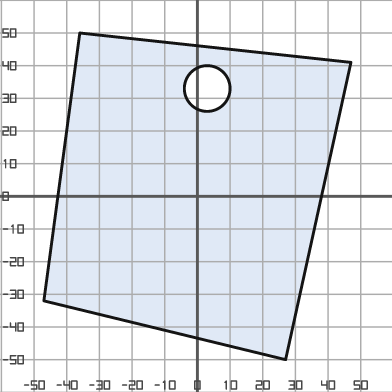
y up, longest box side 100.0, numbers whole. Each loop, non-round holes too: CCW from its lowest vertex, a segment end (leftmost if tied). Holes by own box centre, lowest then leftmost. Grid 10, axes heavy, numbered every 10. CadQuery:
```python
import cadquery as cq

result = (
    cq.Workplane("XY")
    .moveTo(27.0, -50.0)
    .lineTo(47.0, 41.0)
    .lineTo(-36.0, 50.0)
    .lineTo(-47.0, -32.0)
    .close()
    .moveTo(3.0, 33.0)
    .circle(7.0)
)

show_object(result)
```